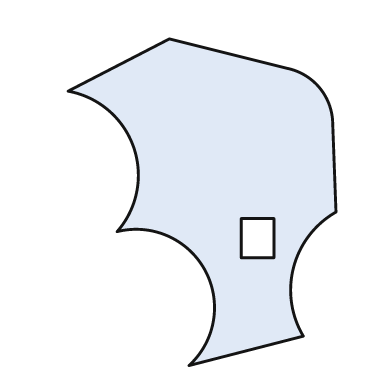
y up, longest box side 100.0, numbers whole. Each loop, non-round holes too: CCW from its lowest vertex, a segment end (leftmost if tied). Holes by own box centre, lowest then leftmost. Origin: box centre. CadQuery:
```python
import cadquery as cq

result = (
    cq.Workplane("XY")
    .moveTo(-4.0, -50.0)
    .lineTo(31.0, -41.0)
    .threePointArc((28.0, -20.0), (41.0, -3.0))
    .lineTo(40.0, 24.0)
    .threePointArc((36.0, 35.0), (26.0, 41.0))
    .lineTo(-10.0, 50.0)
    .lineTo(-41.0, 34.0)
    .threePointArc((-21.0, 17.0), (-26.0, -9.0))
    .threePointArc((1.0, -21.0), (-4.0, -50.0))
    .close()
    .moveTo(12.0, -17.0)
    .lineTo(22.0, -17.0)
    .lineTo(22.0, -5.0)
    .lineTo(12.0, -5.0)
    .close()
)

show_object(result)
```